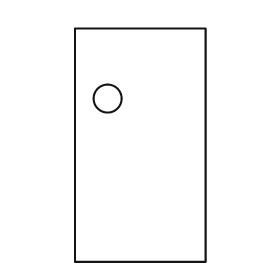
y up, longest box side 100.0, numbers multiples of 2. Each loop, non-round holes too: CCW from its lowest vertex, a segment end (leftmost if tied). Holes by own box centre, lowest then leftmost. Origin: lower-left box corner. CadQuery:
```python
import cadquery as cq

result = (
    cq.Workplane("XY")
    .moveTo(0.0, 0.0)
    .lineTo(56.0, 0.0)
    .lineTo(56.0, 100.0)
    .lineTo(0.0, 100.0)
    .close()
    .moveTo(14.0, 70.0)
    .circle(6.0)
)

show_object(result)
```